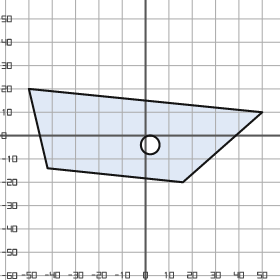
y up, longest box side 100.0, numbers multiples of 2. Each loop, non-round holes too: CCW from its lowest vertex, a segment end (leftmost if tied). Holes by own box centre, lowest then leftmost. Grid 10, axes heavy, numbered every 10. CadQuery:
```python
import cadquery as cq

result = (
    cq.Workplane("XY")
    .moveTo(16.0, -20.0)
    .lineTo(50.0, 10.0)
    .lineTo(-50.0, 20.0)
    .lineTo(-42.0, -14.0)
    .close()
    .moveTo(2.0, -4.0)
    .circle(4.0)
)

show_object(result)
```